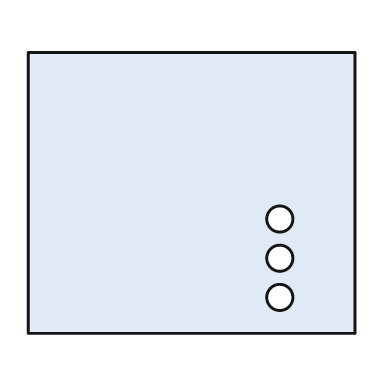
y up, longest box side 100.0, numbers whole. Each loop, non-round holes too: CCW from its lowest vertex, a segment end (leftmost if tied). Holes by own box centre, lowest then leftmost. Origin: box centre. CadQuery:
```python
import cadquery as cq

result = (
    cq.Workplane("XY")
    .moveTo(-50.0, -43.0)
    .lineTo(50.0, -43.0)
    .lineTo(50.0, 43.0)
    .lineTo(-50.0, 43.0)
    .close()
    .moveTo(27.0, -32.0)
    .circle(4.0)
    .moveTo(27.0, -20.0)
    .circle(4.0)
    .moveTo(27.0, -8.0)
    .circle(4.0)
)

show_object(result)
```